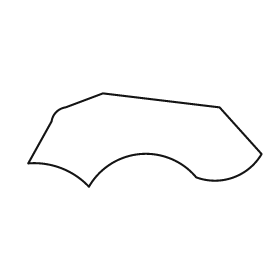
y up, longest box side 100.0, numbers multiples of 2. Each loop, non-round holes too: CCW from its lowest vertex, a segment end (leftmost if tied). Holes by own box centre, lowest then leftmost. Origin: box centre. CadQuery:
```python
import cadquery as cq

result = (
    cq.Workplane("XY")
    .moveTo(-24.0, -20.0)
    .threePointArc((-2.0, -6.0), (22.0, -16.0))
    .threePointArc((38.0, -16.0), (50.0, -6.0))
    .lineTo(32.0, 14.0)
    .lineTo(-18.0, 20.0)
    .lineTo(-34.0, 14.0)
    .threePointArc((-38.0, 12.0), (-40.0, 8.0))
    .lineTo(-50.0, -10.0)
    .threePointArc((-36.0, -12.0), (-24.0, -20.0))
    .close()
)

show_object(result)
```